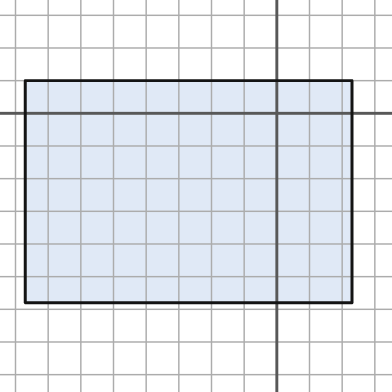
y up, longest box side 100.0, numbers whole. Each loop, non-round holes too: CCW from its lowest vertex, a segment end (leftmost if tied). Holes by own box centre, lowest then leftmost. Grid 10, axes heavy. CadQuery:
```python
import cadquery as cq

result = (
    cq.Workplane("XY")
    .moveTo(-77.0, -58.0)
    .lineTo(23.0, -58.0)
    .lineTo(23.0, 10.0)
    .lineTo(-77.0, 10.0)
    .close()
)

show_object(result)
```